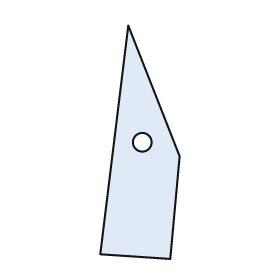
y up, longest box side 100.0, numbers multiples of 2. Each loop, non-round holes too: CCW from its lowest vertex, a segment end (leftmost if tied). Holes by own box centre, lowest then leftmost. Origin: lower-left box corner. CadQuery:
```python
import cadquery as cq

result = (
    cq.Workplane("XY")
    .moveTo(30.0, 0.0)
    .lineTo(34.0, 44.0)
    .lineTo(12.0, 100.0)
    .lineTo(0.0, 2.0)
    .close()
    .moveTo(18.0, 50.0)
    .circle(4.0)
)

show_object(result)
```